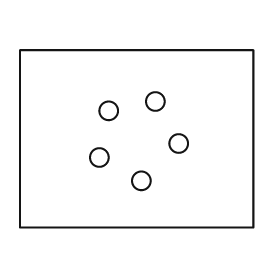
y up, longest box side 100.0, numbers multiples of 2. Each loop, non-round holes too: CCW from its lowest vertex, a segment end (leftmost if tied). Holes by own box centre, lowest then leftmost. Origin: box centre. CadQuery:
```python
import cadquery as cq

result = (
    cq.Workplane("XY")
    .moveTo(-50.0, -38.0)
    .lineTo(50.0, -38.0)
    .lineTo(50.0, 38.0)
    .lineTo(-50.0, 38.0)
    .close()
    .moveTo(2.0, -18.0)
    .circle(4.0)
    .moveTo(-16.0, -8.0)
    .circle(4.0)
    .moveTo(18.0, -2.0)
    .circle(4.0)
    .moveTo(-12.0, 12.0)
    .circle(4.0)
    .moveTo(8.0, 16.0)
    .circle(4.0)
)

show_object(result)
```